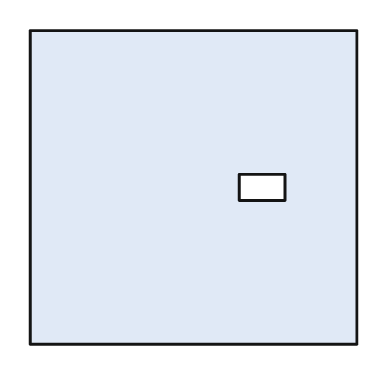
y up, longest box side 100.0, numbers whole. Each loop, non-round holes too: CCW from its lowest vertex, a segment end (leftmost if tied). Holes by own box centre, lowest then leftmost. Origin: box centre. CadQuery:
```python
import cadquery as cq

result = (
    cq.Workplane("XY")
    .moveTo(-50.0, -48.0)
    .lineTo(50.0, -48.0)
    .lineTo(50.0, 48.0)
    .lineTo(-50.0, 48.0)
    .close()
    .moveTo(14.0, -4.0)
    .lineTo(28.0, -4.0)
    .lineTo(28.0, 4.0)
    .lineTo(14.0, 4.0)
    .close()
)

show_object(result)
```